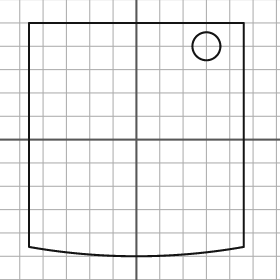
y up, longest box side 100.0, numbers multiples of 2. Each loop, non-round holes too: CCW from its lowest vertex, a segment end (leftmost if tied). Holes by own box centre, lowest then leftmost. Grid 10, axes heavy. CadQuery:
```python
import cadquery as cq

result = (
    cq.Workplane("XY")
    .moveTo(-46.0, -46.0)
    .threePointArc((0.0, -50.0), (46.0, -46.0))
    .lineTo(46.0, 50.0)
    .lineTo(-46.0, 50.0)
    .close()
    .moveTo(30.0, 40.0)
    .circle(6.0)
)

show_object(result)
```